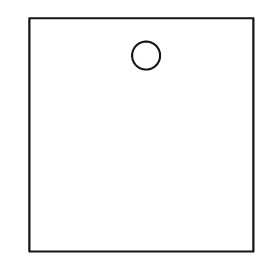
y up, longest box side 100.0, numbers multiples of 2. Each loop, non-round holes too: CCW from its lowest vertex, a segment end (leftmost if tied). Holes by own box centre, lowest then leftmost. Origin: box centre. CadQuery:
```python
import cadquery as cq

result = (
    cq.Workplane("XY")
    .moveTo(-48.0, -50.0)
    .lineTo(48.0, -50.0)
    .lineTo(48.0, 50.0)
    .lineTo(-48.0, 50.0)
    .close()
    .moveTo(2.0, 34.0)
    .circle(6.0)
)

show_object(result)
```